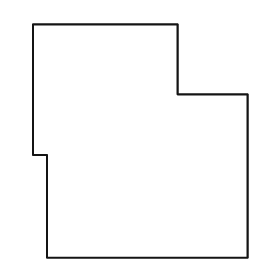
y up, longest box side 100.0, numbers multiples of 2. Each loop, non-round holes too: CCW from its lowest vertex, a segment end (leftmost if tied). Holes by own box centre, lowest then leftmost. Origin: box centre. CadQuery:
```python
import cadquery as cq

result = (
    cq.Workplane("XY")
    .moveTo(-40.0, -50.0)
    .lineTo(46.0, -50.0)
    .lineTo(46.0, 20.0)
    .lineTo(16.0, 20.0)
    .lineTo(16.0, 50.0)
    .lineTo(-46.0, 50.0)
    .lineTo(-46.0, -6.0)
    .lineTo(-40.0, -6.0)
    .close()
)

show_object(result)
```